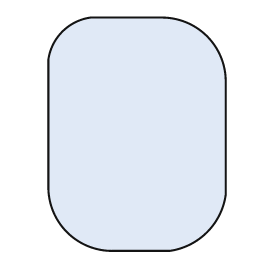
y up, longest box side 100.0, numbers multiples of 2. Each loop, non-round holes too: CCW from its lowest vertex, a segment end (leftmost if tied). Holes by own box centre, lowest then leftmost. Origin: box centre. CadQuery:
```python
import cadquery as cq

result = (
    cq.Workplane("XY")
    .moveTo(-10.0, -50.0)
    .lineTo(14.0, -50.0)
    .threePointArc((30.0, -42.0), (38.0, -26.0))
    .lineTo(38.0, 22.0)
    .threePointArc((30.0, 42.0), (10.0, 50.0))
    .lineTo(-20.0, 50.0)
    .threePointArc((-32.0, 44.0), (-38.0, 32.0))
    .lineTo(-38.0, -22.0)
    .threePointArc((-30.0, -42.0), (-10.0, -50.0))
    .close()
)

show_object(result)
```